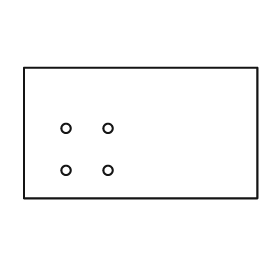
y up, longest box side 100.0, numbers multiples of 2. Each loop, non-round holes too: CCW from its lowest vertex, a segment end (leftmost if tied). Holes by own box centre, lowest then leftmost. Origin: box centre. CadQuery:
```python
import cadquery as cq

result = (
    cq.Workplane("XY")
    .moveTo(-50.0, -28.0)
    .lineTo(50.0, -28.0)
    .lineTo(50.0, 28.0)
    .lineTo(-50.0, 28.0)
    .close()
    .moveTo(-32.0, -16.0)
    .circle(2.0)
    .moveTo(-14.0, -16.0)
    .circle(2.0)
    .moveTo(-32.0, 2.0)
    .circle(2.0)
    .moveTo(-14.0, 2.0)
    .circle(2.0)
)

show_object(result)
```